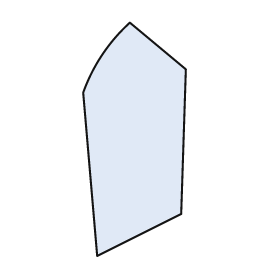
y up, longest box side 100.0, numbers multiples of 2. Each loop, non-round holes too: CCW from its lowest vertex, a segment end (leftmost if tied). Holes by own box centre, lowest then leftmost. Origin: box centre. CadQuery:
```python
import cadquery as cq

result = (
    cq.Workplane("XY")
    .moveTo(-16.0, -50.0)
    .lineTo(20.0, -32.0)
    .lineTo(22.0, 30.0)
    .lineTo(-2.0, 50.0)
    .threePointArc((-14.0, 36.0), (-22.0, 20.0))
    .close()
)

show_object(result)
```